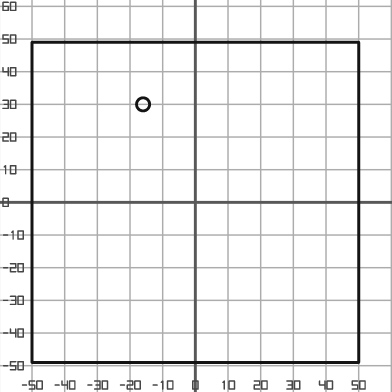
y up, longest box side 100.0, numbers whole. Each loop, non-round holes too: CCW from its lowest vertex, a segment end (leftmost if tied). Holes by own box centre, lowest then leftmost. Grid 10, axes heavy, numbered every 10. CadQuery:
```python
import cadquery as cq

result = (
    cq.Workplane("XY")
    .moveTo(-50.0, -49.0)
    .lineTo(50.0, -49.0)
    .lineTo(50.0, 49.0)
    .lineTo(-50.0, 49.0)
    .close()
    .moveTo(-16.0, 30.0)
    .circle(2.0)
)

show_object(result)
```